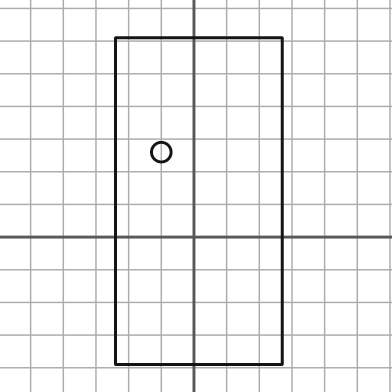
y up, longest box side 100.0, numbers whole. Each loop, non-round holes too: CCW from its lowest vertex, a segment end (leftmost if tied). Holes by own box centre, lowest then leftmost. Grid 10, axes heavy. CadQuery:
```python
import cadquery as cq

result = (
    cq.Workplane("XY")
    .moveTo(-24.0, -39.0)
    .lineTo(27.0, -39.0)
    .lineTo(27.0, 61.0)
    .lineTo(-24.0, 61.0)
    .close()
    .moveTo(-10.0, 26.0)
    .circle(3.0)
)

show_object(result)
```